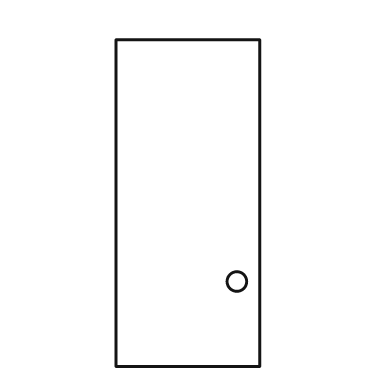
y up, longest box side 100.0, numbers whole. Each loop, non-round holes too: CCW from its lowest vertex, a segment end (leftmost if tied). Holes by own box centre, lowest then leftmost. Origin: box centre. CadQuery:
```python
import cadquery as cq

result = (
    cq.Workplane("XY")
    .moveTo(-22.0, -50.0)
    .lineTo(22.0, -50.0)
    .lineTo(22.0, 50.0)
    .lineTo(-22.0, 50.0)
    .close()
    .moveTo(15.0, -24.0)
    .circle(3.0)
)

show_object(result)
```